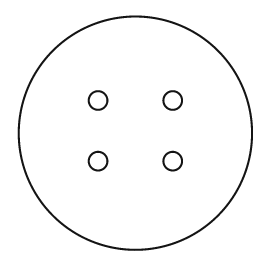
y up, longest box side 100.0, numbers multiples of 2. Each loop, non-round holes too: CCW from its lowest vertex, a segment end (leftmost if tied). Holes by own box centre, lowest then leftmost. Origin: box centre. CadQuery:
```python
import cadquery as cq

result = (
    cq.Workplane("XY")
    .moveTo(0.0, 0.0)
    .circle(50.0)
    .moveTo(-16.0, -12.0)
    .circle(4.0)
    .moveTo(16.0, -12.0)
    .circle(4.0)
    .moveTo(-16.0, 14.0)
    .circle(4.0)
    .moveTo(16.0, 14.0)
    .circle(4.0)
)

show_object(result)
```